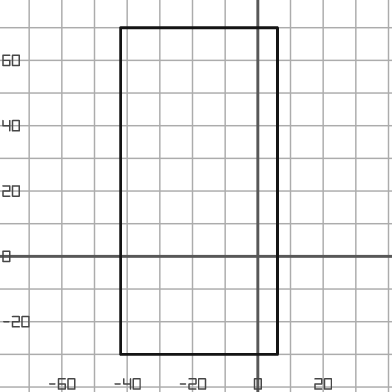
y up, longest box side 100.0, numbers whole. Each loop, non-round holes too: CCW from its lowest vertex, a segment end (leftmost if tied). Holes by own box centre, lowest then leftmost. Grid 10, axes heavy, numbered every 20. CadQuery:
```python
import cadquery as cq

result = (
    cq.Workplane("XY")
    .moveTo(-42.0, -30.0)
    .lineTo(6.0, -30.0)
    .lineTo(6.0, 70.0)
    .lineTo(-42.0, 70.0)
    .close()
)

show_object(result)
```